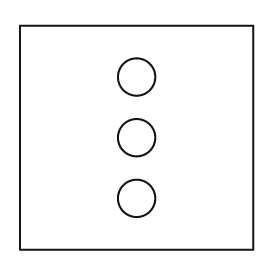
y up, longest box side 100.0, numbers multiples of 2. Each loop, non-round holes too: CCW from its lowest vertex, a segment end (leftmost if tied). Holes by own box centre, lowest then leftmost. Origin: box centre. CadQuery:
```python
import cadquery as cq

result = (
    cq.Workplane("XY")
    .moveTo(-50.0, -48.0)
    .lineTo(50.0, -48.0)
    .lineTo(50.0, 48.0)
    .lineTo(-50.0, 48.0)
    .close()
    .moveTo(0.0, -26.0)
    .circle(8.0)
    .moveTo(0.0, 0.0)
    .circle(8.0)
    .moveTo(0.0, 26.0)
    .circle(8.0)
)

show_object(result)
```